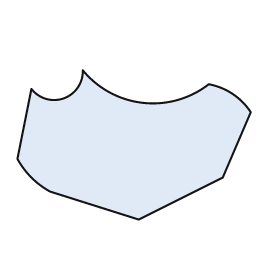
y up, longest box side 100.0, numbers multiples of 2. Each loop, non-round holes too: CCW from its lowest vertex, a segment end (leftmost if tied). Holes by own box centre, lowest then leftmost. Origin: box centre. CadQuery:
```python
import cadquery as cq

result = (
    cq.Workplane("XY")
    .moveTo(2.0, -32.0)
    .lineTo(38.0, -14.0)
    .lineTo(50.0, 14.0)
    .threePointArc((42.0, 22.0), (32.0, 26.0))
    .threePointArc((4.0, 18.0), (-22.0, 32.0))
    .threePointArc((-30.0, 20.0), (-44.0, 24.0))
    .lineTo(-50.0, -6.0)
    .threePointArc((-44.0, -14.0), (-36.0, -20.0))
    .close()
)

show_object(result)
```